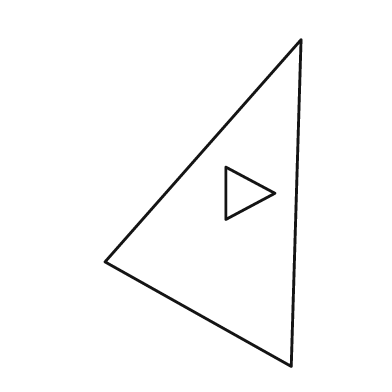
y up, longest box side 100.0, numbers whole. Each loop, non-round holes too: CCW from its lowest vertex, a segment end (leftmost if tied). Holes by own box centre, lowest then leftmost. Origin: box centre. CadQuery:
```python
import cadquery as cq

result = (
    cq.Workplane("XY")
    .moveTo(27.0, -50.0)
    .lineTo(30.0, 50.0)
    .lineTo(-30.0, -18.0)
    .close()
    .moveTo(7.0, -5.0)
    .lineTo(22.0, 3.0)
    .lineTo(7.0, 11.0)
    .close()
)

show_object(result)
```